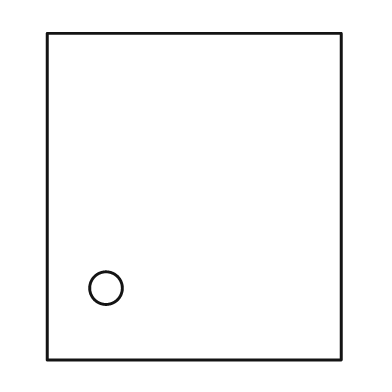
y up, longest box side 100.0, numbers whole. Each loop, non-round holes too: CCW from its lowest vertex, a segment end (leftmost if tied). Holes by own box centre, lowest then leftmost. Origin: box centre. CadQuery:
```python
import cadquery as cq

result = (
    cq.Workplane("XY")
    .moveTo(-45.0, -50.0)
    .lineTo(45.0, -50.0)
    .lineTo(45.0, 50.0)
    .lineTo(-45.0, 50.0)
    .close()
    .moveTo(-27.0, -28.0)
    .circle(5.0)
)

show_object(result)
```